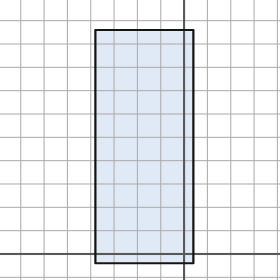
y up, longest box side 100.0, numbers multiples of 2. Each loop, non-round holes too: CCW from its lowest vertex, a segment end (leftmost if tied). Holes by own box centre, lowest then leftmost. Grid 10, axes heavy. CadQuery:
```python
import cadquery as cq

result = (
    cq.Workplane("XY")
    .moveTo(-38.0, -4.0)
    .lineTo(4.0, -4.0)
    .lineTo(4.0, 96.0)
    .lineTo(-38.0, 96.0)
    .close()
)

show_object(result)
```